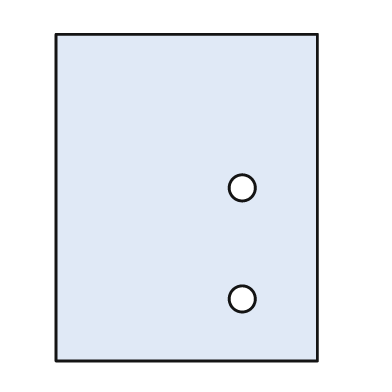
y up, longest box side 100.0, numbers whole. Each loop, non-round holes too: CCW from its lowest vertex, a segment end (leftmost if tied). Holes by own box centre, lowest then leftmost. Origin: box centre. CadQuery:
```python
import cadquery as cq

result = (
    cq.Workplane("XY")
    .moveTo(-40.0, -50.0)
    .lineTo(40.0, -50.0)
    .lineTo(40.0, 50.0)
    .lineTo(-40.0, 50.0)
    .close()
    .moveTo(17.0, -31.0)
    .circle(4.0)
    .moveTo(17.0, 3.0)
    .circle(4.0)
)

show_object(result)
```